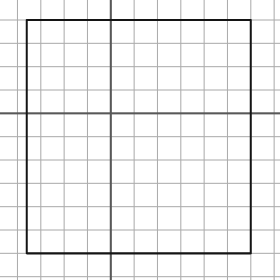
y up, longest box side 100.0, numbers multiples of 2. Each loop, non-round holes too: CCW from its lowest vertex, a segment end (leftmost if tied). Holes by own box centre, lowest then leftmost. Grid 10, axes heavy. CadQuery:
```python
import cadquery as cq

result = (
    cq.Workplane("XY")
    .moveTo(-36.0, -60.0)
    .lineTo(60.0, -60.0)
    .lineTo(60.0, 40.0)
    .lineTo(-36.0, 40.0)
    .close()
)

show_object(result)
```